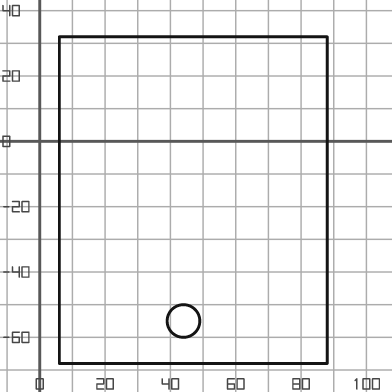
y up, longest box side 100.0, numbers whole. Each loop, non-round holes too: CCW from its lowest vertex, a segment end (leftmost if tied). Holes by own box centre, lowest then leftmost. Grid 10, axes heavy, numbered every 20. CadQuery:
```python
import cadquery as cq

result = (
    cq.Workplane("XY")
    .moveTo(6.0, -68.0)
    .lineTo(88.0, -68.0)
    .lineTo(88.0, 32.0)
    .lineTo(6.0, 32.0)
    .close()
    .moveTo(44.0, -55.0)
    .circle(5.0)
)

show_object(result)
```